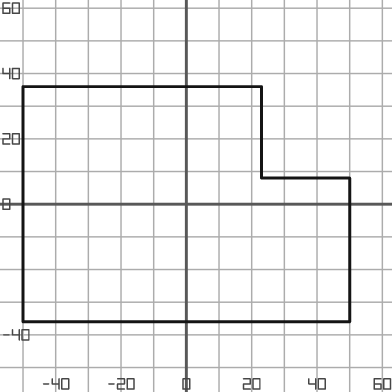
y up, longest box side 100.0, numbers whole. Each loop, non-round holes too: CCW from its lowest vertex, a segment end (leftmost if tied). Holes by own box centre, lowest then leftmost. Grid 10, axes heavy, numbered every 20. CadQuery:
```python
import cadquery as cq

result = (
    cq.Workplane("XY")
    .moveTo(-50.0, -36.0)
    .lineTo(50.0, -36.0)
    .lineTo(50.0, 8.0)
    .lineTo(23.0, 8.0)
    .lineTo(23.0, 36.0)
    .lineTo(-50.0, 36.0)
    .close()
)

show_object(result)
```